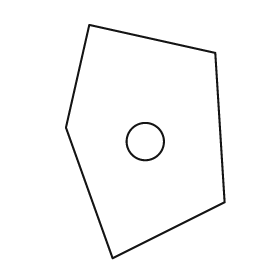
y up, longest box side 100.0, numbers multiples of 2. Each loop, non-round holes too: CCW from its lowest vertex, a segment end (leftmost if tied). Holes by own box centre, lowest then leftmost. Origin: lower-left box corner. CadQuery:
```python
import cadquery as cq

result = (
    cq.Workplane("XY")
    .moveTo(20.0, 0.0)
    .lineTo(68.0, 24.0)
    .lineTo(64.0, 88.0)
    .lineTo(10.0, 100.0)
    .lineTo(0.0, 56.0)
    .close()
    .moveTo(34.0, 50.0)
    .circle(8.0)
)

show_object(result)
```